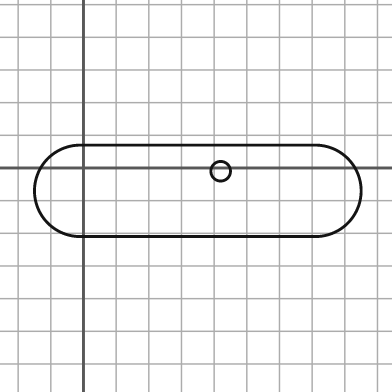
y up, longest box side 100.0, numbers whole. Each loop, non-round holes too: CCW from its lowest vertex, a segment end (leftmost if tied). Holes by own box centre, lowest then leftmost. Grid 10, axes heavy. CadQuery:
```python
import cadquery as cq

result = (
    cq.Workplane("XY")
    .moveTo(-1.0, -21.0)
    .lineTo(71.0, -21.0)
    .threePointArc((85.0, -7.0), (71.0, 7.0))
    .lineTo(-1.0, 7.0)
    .threePointArc((-15.0, -7.0), (-1.0, -21.0))
    .close()
    .moveTo(42.0, -1.0)
    .circle(3.0)
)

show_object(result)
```